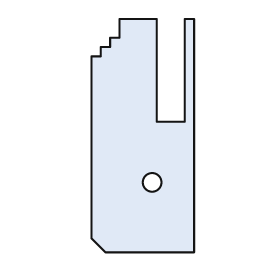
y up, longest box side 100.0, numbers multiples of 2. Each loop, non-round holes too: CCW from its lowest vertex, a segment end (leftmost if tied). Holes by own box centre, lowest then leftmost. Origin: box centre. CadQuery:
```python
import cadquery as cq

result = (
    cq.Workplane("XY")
    .moveTo(-16.0, -50.0)
    .lineTo(22.0, -50.0)
    .lineTo(22.0, 50.0)
    .lineTo(18.0, 50.0)
    .lineTo(18.0, 6.0)
    .lineTo(6.0, 6.0)
    .lineTo(6.0, 50.0)
    .lineTo(-10.0, 50.0)
    .lineTo(-10.0, 42.0)
    .lineTo(-14.0, 42.0)
    .lineTo(-14.0, 38.0)
    .lineTo(-18.0, 38.0)
    .lineTo(-18.0, 34.0)
    .lineTo(-22.0, 34.0)
    .lineTo(-22.0, -44.0)
    .close()
    .moveTo(4.0, -20.0)
    .circle(4.0)
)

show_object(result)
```